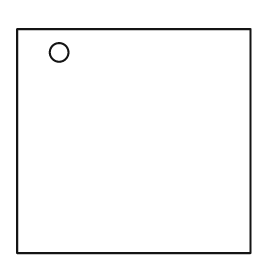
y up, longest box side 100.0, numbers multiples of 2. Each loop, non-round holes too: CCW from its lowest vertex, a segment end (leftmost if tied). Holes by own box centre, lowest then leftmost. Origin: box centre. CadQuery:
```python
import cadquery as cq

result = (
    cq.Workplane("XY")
    .moveTo(-50.0, -48.0)
    .lineTo(50.0, -48.0)
    .lineTo(50.0, 48.0)
    .lineTo(-50.0, 48.0)
    .close()
    .moveTo(-32.0, 38.0)
    .circle(4.0)
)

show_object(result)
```